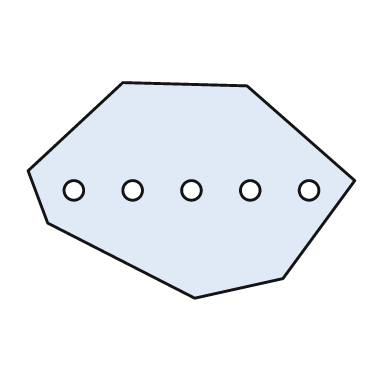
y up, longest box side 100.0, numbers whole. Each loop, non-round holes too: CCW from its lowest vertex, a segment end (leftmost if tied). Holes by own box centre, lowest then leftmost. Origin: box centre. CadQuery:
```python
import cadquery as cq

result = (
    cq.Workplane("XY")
    .moveTo(1.0, -33.0)
    .lineTo(28.0, -27.0)
    .lineTo(50.0, 3.0)
    .lineTo(17.0, 32.0)
    .lineTo(-21.0, 33.0)
    .lineTo(-50.0, 6.0)
    .lineTo(-44.0, -10.0)
    .close()
    .moveTo(-36.0, 0.0)
    .circle(3.0)
    .moveTo(-18.0, 0.0)
    .circle(3.0)
    .moveTo(0.0, 0.0)
    .circle(3.0)
    .moveTo(18.0, 0.0)
    .circle(3.0)
    .moveTo(36.0, 0.0)
    .circle(3.0)
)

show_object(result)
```